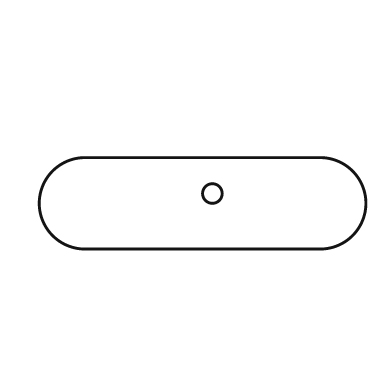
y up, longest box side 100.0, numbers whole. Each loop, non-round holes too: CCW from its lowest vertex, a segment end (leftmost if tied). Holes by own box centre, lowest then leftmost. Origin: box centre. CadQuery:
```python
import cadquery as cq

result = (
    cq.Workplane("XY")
    .moveTo(-36.0, -14.0)
    .lineTo(36.0, -14.0)
    .threePointArc((50.0, 0.0), (36.0, 14.0))
    .lineTo(-36.0, 14.0)
    .threePointArc((-50.0, 0.0), (-36.0, -14.0))
    .close()
    .moveTo(3.0, 3.0)
    .circle(3.0)
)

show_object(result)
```